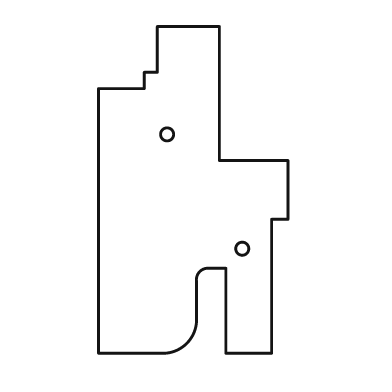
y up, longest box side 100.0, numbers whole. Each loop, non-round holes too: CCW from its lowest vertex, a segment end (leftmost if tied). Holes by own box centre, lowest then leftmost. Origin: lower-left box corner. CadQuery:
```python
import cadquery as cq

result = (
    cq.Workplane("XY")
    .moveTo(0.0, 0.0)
    .lineTo(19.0, 0.0)
    .threePointArc((27.0, 3.0), (30.0, 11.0))
    .lineTo(30.0, 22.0)
    .threePointArc((31.0, 25.0), (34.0, 26.0))
    .lineTo(39.0, 26.0)
    .lineTo(39.0, 0.0)
    .lineTo(53.0, 0.0)
    .lineTo(53.0, 41.0)
    .lineTo(58.0, 41.0)
    .lineTo(58.0, 59.0)
    .lineTo(37.0, 59.0)
    .lineTo(37.0, 100.0)
    .lineTo(18.0, 100.0)
    .lineTo(18.0, 86.0)
    .lineTo(14.0, 86.0)
    .lineTo(14.0, 81.0)
    .lineTo(0.0, 81.0)
    .close()
    .moveTo(44.0, 32.0)
    .circle(2.0)
    .moveTo(21.0, 67.0)
    .circle(2.0)
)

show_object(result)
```